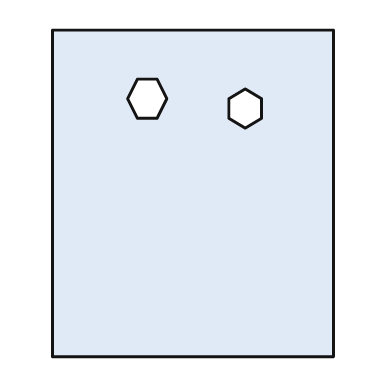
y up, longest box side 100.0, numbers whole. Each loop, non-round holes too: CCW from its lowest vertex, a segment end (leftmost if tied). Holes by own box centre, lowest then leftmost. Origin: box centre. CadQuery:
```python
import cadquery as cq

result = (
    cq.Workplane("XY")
    .moveTo(-43.0, -50.0)
    .lineTo(43.0, -50.0)
    .lineTo(43.0, 50.0)
    .lineTo(-43.0, 50.0)
    .close()
    .moveTo(16.0, 20.0)
    .lineTo(21.0, 23.0)
    .lineTo(21.0, 29.0)
    .lineTo(16.0, 32.0)
    .lineTo(11.0, 29.0)
    .lineTo(11.0, 23.0)
    .close()
    .moveTo(-17.0, 23.0)
    .lineTo(-11.0, 23.0)
    .lineTo(-8.0, 29.0)
    .lineTo(-11.0, 35.0)
    .lineTo(-17.0, 35.0)
    .lineTo(-20.0, 29.0)
    .close()
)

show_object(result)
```